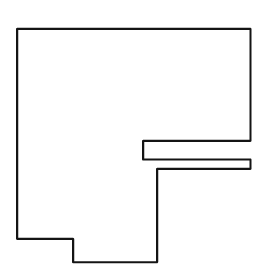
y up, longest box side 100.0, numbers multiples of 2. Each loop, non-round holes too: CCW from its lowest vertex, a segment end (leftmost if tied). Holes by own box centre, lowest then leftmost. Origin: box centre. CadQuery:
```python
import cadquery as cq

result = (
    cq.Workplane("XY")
    .moveTo(-26.0, -50.0)
    .lineTo(10.0, -50.0)
    .lineTo(10.0, -10.0)
    .lineTo(50.0, -10.0)
    .lineTo(50.0, -6.0)
    .lineTo(4.0, -6.0)
    .lineTo(4.0, 2.0)
    .lineTo(50.0, 2.0)
    .lineTo(50.0, 50.0)
    .lineTo(-50.0, 50.0)
    .lineTo(-50.0, -40.0)
    .lineTo(-26.0, -40.0)
    .close()
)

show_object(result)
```